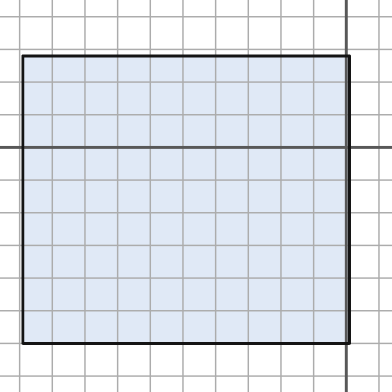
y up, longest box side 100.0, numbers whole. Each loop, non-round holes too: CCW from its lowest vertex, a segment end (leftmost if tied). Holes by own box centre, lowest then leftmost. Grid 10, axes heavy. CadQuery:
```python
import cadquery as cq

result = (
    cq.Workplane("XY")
    .moveTo(-99.0, -60.0)
    .lineTo(1.0, -60.0)
    .lineTo(1.0, 28.0)
    .lineTo(-99.0, 28.0)
    .close()
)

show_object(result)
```